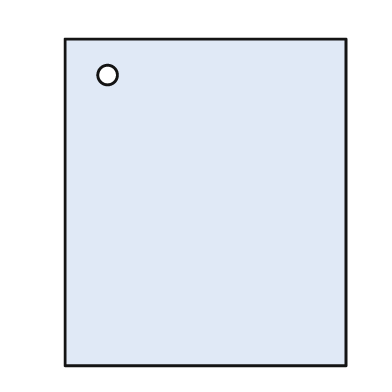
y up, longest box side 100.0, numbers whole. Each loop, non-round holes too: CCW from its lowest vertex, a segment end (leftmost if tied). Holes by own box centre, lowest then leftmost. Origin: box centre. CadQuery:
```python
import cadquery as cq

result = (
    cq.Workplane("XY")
    .moveTo(-43.0, -50.0)
    .lineTo(43.0, -50.0)
    .lineTo(43.0, 50.0)
    .lineTo(-43.0, 50.0)
    .close()
    .moveTo(-30.0, 39.0)
    .circle(3.0)
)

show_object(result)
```